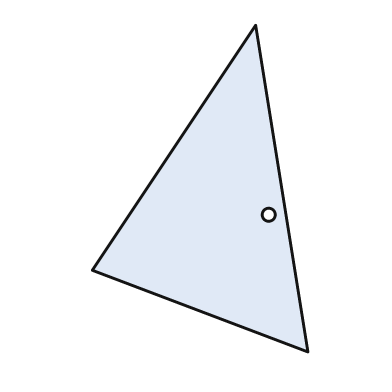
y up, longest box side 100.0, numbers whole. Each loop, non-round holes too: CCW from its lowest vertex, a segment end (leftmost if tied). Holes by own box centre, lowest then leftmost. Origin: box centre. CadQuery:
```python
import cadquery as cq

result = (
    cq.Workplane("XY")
    .moveTo(33.0, -50.0)
    .lineTo(17.0, 50.0)
    .lineTo(-33.0, -25.0)
    .close()
    .moveTo(21.0, -8.0)
    .circle(2.0)
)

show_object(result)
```